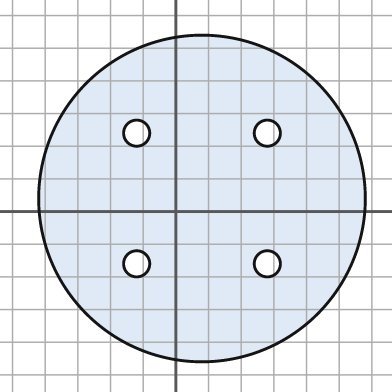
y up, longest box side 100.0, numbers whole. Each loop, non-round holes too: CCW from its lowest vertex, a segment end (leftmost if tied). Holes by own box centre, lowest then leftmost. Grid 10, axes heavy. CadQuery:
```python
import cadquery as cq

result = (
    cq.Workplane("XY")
    .moveTo(8.0, 4.0)
    .circle(50.0)
    .moveTo(-12.0, -16.0)
    .circle(4.0)
    .moveTo(28.0, -16.0)
    .circle(4.0)
    .moveTo(-12.0, 24.0)
    .circle(4.0)
    .moveTo(28.0, 24.0)
    .circle(4.0)
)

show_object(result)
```